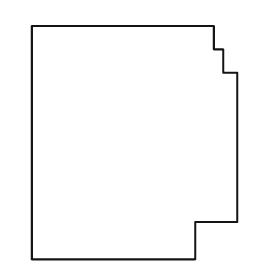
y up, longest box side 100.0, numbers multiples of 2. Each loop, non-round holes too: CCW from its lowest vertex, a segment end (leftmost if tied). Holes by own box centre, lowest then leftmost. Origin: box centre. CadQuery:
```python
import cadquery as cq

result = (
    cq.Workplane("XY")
    .moveTo(-44.0, -50.0)
    .lineTo(26.0, -50.0)
    .lineTo(26.0, -34.0)
    .lineTo(44.0, -34.0)
    .lineTo(44.0, 30.0)
    .lineTo(38.0, 30.0)
    .lineTo(38.0, 40.0)
    .lineTo(34.0, 40.0)
    .lineTo(34.0, 50.0)
    .lineTo(-44.0, 50.0)
    .close()
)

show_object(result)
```